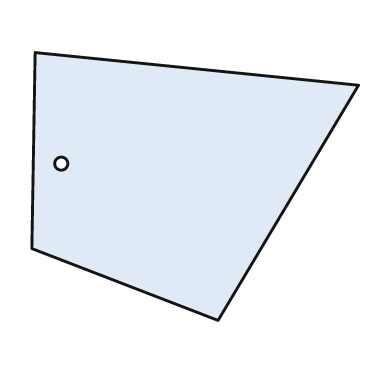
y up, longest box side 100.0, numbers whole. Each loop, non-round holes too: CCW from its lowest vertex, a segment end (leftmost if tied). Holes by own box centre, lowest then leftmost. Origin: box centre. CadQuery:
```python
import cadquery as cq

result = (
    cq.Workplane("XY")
    .moveTo(7.0, -41.0)
    .lineTo(50.0, 31.0)
    .lineTo(-49.0, 41.0)
    .lineTo(-50.0, -19.0)
    .close()
    .moveTo(-41.0, 7.0)
    .circle(2.0)
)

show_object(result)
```